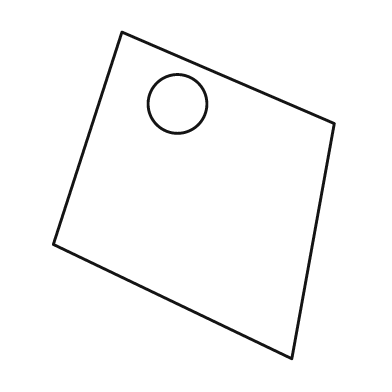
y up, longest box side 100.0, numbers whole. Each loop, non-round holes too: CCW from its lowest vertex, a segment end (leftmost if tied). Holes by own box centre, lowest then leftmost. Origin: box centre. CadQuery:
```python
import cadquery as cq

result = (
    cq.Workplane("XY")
    .moveTo(30.0, -50.0)
    .lineTo(43.0, 22.0)
    .lineTo(-22.0, 50.0)
    .lineTo(-43.0, -15.0)
    .close()
    .moveTo(-5.0, 28.0)
    .circle(9.0)
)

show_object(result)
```